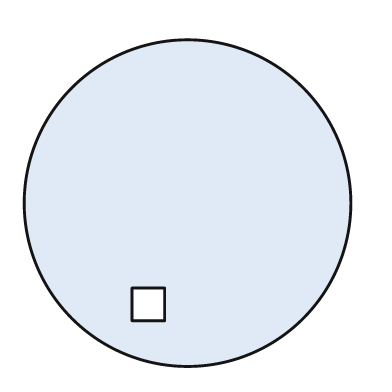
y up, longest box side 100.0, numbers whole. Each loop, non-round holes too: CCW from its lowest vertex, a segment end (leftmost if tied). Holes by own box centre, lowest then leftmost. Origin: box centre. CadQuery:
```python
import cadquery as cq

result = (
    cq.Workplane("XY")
    .moveTo(0.0, 0.0)
    .circle(50.0)
    .moveTo(-17.0, -36.0)
    .lineTo(-7.0, -36.0)
    .lineTo(-7.0, -26.0)
    .lineTo(-17.0, -26.0)
    .close()
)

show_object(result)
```